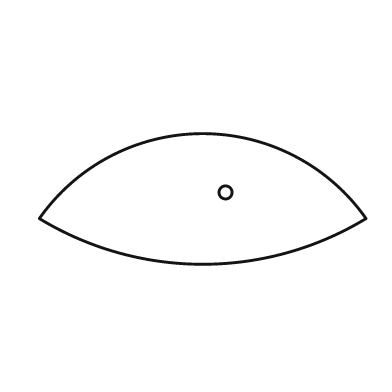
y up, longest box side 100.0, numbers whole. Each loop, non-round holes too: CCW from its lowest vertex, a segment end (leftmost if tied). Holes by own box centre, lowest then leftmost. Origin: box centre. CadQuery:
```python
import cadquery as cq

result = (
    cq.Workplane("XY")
    .moveTo(-50.0, -6.0)
    .threePointArc((0.0, -20.0), (50.0, -6.0))
    .threePointArc((0.0, 20.0), (-50.0, -6.0))
    .close()
    .moveTo(7.0, 2.0)
    .circle(2.0)
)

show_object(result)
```